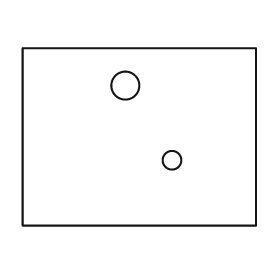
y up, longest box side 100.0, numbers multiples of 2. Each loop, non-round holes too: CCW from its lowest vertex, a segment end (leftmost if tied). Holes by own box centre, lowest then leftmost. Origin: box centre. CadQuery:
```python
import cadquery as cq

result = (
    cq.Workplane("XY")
    .moveTo(-50.0, -38.0)
    .lineTo(50.0, -38.0)
    .lineTo(50.0, 38.0)
    .lineTo(-50.0, 38.0)
    .close()
    .moveTo(14.0, -10.0)
    .circle(4.0)
    .moveTo(-6.0, 22.0)
    .circle(6.0)
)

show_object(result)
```